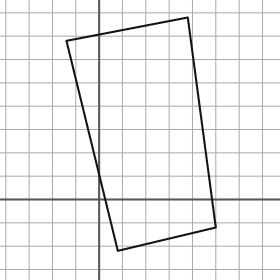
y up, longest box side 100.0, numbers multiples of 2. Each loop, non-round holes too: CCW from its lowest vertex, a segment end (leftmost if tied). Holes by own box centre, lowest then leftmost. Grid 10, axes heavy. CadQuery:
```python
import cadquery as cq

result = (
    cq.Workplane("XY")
    .moveTo(8.0, -22.0)
    .lineTo(50.0, -12.0)
    .lineTo(38.0, 78.0)
    .lineTo(-14.0, 68.0)
    .close()
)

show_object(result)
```